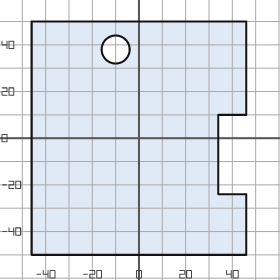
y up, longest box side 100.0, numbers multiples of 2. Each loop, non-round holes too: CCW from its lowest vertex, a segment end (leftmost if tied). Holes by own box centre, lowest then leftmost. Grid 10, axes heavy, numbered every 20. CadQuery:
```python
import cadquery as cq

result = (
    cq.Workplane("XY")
    .moveTo(-46.0, -50.0)
    .lineTo(46.0, -50.0)
    .lineTo(46.0, -24.0)
    .lineTo(34.0, -24.0)
    .lineTo(34.0, 10.0)
    .lineTo(46.0, 10.0)
    .lineTo(46.0, 50.0)
    .lineTo(-46.0, 50.0)
    .close()
    .moveTo(-10.0, 38.0)
    .circle(6.0)
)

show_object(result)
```